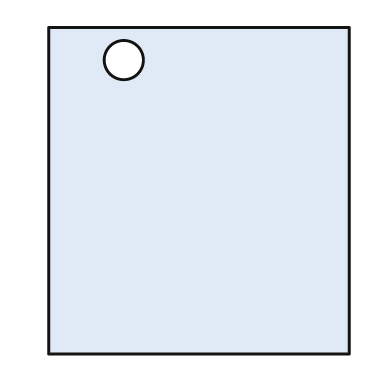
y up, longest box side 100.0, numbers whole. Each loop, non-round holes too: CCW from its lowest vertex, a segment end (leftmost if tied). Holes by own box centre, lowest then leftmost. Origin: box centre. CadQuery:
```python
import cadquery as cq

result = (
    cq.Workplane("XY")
    .moveTo(-46.0, -50.0)
    .lineTo(46.0, -50.0)
    .lineTo(46.0, 50.0)
    .lineTo(-46.0, 50.0)
    .close()
    .moveTo(-23.0, 40.0)
    .circle(6.0)
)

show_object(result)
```